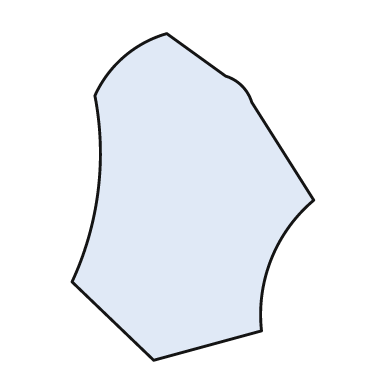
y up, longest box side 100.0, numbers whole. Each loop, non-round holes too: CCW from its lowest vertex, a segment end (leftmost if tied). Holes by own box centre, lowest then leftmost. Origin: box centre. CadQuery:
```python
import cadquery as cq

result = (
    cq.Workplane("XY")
    .moveTo(-12.0, -50.0)
    .lineTo(21.0, -41.0)
    .threePointArc((24.0, -19.0), (37.0, -1.0))
    .lineTo(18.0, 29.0)
    .threePointArc((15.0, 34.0), (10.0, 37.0))
    .lineTo(-8.0, 50.0)
    .threePointArc((-21.0, 43.0), (-30.0, 31.0))
    .threePointArc((-29.0, 2.0), (-37.0, -26.0))
    .close()
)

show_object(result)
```